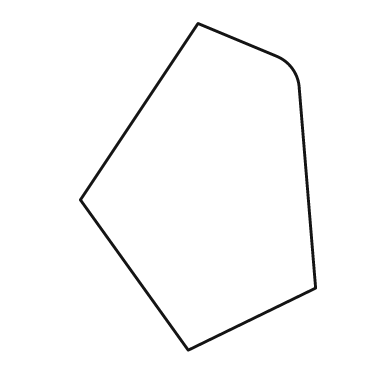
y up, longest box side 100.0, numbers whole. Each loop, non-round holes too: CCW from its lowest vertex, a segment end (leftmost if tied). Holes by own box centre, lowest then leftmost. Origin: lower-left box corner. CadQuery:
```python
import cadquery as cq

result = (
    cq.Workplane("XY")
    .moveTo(33.0, 0.0)
    .lineTo(72.0, 19.0)
    .lineTo(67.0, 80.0)
    .threePointArc((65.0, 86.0), (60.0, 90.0))
    .lineTo(36.0, 100.0)
    .lineTo(0.0, 46.0)
    .close()
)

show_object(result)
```